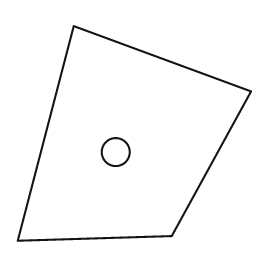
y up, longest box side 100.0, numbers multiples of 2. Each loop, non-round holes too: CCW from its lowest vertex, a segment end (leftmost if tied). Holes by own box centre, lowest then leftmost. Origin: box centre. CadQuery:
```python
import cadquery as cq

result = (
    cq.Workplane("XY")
    .moveTo(-50.0, -46.0)
    .lineTo(16.0, -44.0)
    .lineTo(50.0, 18.0)
    .lineTo(-26.0, 46.0)
    .close()
    .moveTo(-8.0, -8.0)
    .circle(6.0)
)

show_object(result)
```